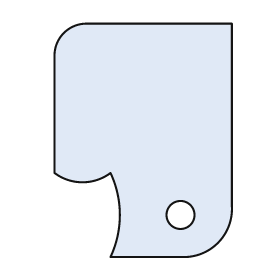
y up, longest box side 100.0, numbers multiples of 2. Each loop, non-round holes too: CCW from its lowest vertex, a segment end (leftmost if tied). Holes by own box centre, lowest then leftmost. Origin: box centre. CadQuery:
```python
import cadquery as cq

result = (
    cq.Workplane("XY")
    .moveTo(-14.0, -50.0)
    .lineTo(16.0, -50.0)
    .threePointArc((32.0, -44.0), (38.0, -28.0))
    .lineTo(38.0, 50.0)
    .lineTo(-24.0, 50.0)
    .threePointArc((-34.0, 46.0), (-38.0, 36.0))
    .lineTo(-38.0, -14.0)
    .threePointArc((-26.0, -18.0), (-14.0, -14.0))
    .threePointArc((-10.0, -32.0), (-14.0, -50.0))
    .close()
    .moveTo(16.0, -32.0)
    .circle(6.0)
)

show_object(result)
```